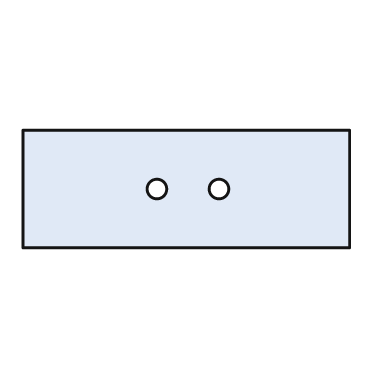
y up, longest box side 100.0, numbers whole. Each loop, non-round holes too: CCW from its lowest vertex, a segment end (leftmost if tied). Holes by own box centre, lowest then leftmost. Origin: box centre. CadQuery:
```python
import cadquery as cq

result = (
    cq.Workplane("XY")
    .moveTo(-50.0, -18.0)
    .lineTo(50.0, -18.0)
    .lineTo(50.0, 18.0)
    .lineTo(-50.0, 18.0)
    .close()
    .moveTo(-9.0, 0.0)
    .circle(3.0)
    .moveTo(10.0, 0.0)
    .circle(3.0)
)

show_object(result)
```